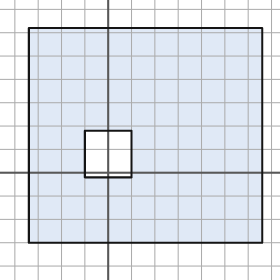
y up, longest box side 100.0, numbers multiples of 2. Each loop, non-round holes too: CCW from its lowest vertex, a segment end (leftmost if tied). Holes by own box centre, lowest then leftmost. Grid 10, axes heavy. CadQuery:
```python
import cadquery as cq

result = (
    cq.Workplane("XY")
    .moveTo(-34.0, -30.0)
    .lineTo(66.0, -30.0)
    .lineTo(66.0, 62.0)
    .lineTo(-34.0, 62.0)
    .close()
    .moveTo(-10.0, -2.0)
    .lineTo(10.0, -2.0)
    .lineTo(10.0, 18.0)
    .lineTo(-10.0, 18.0)
    .close()
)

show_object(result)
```